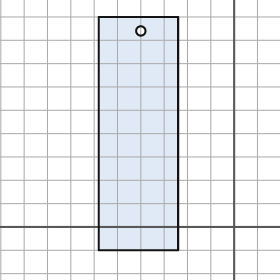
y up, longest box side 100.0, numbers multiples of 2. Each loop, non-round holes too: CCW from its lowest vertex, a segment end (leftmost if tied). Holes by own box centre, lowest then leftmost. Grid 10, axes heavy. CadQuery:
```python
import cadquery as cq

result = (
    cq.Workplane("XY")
    .moveTo(-58.0, -10.0)
    .lineTo(-24.0, -10.0)
    .lineTo(-24.0, 90.0)
    .lineTo(-58.0, 90.0)
    .close()
    .moveTo(-40.0, 84.0)
    .circle(2.0)
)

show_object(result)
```